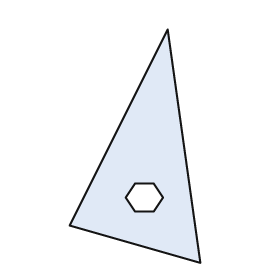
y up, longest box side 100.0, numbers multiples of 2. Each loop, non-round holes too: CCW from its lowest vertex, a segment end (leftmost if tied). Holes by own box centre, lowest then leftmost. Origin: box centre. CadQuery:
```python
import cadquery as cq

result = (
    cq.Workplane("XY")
    .moveTo(28.0, -50.0)
    .lineTo(14.0, 50.0)
    .lineTo(-28.0, -34.0)
    .close()
    .moveTo(0.0, -28.0)
    .lineTo(8.0, -28.0)
    .lineTo(12.0, -22.0)
    .lineTo(8.0, -16.0)
    .lineTo(0.0, -16.0)
    .lineTo(-4.0, -22.0)
    .close()
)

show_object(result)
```